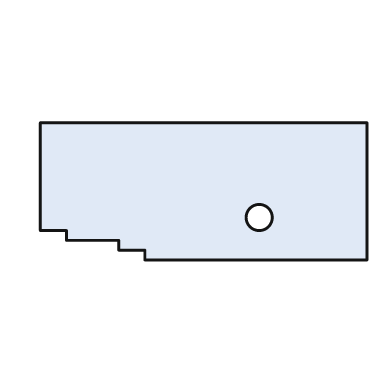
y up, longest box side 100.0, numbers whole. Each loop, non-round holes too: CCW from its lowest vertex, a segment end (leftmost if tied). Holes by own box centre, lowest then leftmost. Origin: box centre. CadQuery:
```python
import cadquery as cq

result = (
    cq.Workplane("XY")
    .moveTo(-18.0, -21.0)
    .lineTo(50.0, -21.0)
    .lineTo(50.0, 21.0)
    .lineTo(-50.0, 21.0)
    .lineTo(-50.0, -12.0)
    .lineTo(-42.0, -12.0)
    .lineTo(-42.0, -15.0)
    .lineTo(-26.0, -15.0)
    .lineTo(-26.0, -18.0)
    .lineTo(-18.0, -18.0)
    .close()
    .moveTo(17.0, -8.0)
    .circle(4.0)
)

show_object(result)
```